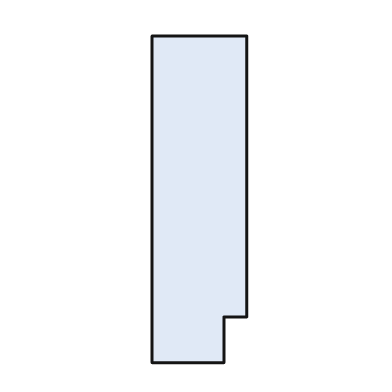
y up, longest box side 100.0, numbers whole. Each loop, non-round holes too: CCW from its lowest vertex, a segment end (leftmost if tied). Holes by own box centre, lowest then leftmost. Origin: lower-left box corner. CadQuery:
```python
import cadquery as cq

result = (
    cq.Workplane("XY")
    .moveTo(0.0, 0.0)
    .lineTo(22.0, 0.0)
    .lineTo(22.0, 14.0)
    .lineTo(29.0, 14.0)
    .lineTo(29.0, 100.0)
    .lineTo(0.0, 100.0)
    .close()
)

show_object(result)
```